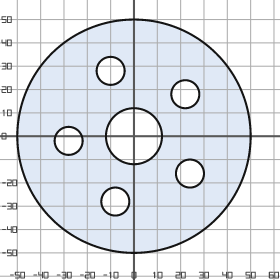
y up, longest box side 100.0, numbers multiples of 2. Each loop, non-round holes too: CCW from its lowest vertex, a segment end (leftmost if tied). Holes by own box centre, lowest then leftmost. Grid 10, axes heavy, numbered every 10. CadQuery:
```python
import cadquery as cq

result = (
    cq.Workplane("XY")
    .moveTo(0.0, 0.0)
    .circle(50.0)
    .moveTo(-8.0, -28.0)
    .circle(6.0)
    .moveTo(24.0, -16.0)
    .circle(6.0)
    .moveTo(-28.0, -2.0)
    .circle(6.0)
    .moveTo(0.0, 0.0)
    .circle(12.0)
    .moveTo(22.0, 18.0)
    .circle(6.0)
    .moveTo(-10.0, 28.0)
    .circle(6.0)
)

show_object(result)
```